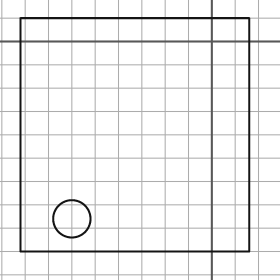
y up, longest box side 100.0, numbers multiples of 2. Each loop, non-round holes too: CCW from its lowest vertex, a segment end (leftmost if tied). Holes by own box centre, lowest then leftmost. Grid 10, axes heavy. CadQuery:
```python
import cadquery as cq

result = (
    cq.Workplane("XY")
    .moveTo(-82.0, -90.0)
    .lineTo(16.0, -90.0)
    .lineTo(16.0, 10.0)
    .lineTo(-82.0, 10.0)
    .close()
    .moveTo(-60.0, -76.0)
    .circle(8.0)
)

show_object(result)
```